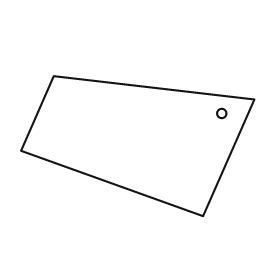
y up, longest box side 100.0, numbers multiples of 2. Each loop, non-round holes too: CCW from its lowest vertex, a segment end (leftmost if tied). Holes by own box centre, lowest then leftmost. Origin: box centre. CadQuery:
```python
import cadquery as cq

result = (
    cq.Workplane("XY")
    .moveTo(28.0, -30.0)
    .lineTo(50.0, 20.0)
    .lineTo(-36.0, 30.0)
    .lineTo(-50.0, -2.0)
    .close()
    .moveTo(36.0, 14.0)
    .circle(2.0)
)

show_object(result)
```